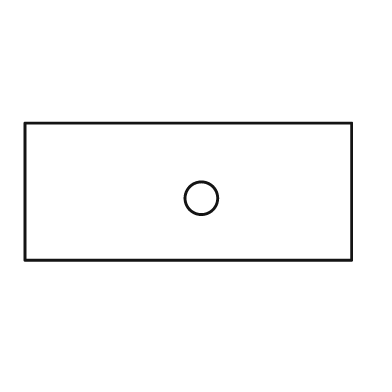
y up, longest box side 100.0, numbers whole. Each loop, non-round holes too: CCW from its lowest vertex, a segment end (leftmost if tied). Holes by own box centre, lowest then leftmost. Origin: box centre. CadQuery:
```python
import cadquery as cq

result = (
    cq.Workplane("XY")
    .moveTo(-50.0, -21.0)
    .lineTo(50.0, -21.0)
    .lineTo(50.0, 21.0)
    .lineTo(-50.0, 21.0)
    .close()
    .moveTo(4.0, -2.0)
    .circle(5.0)
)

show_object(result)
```